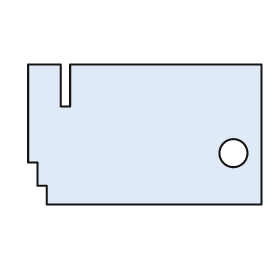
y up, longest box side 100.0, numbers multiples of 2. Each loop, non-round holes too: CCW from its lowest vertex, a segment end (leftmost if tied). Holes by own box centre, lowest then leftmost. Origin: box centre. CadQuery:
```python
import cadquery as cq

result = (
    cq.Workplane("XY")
    .moveTo(-42.0, -30.0)
    .lineTo(50.0, -30.0)
    .lineTo(50.0, 30.0)
    .lineTo(-32.0, 30.0)
    .lineTo(-32.0, 12.0)
    .lineTo(-36.0, 12.0)
    .lineTo(-36.0, 30.0)
    .lineTo(-50.0, 30.0)
    .lineTo(-50.0, -12.0)
    .lineTo(-46.0, -12.0)
    .lineTo(-46.0, -22.0)
    .lineTo(-42.0, -22.0)
    .close()
    .moveTo(38.0, -8.0)
    .circle(6.0)
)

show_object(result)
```